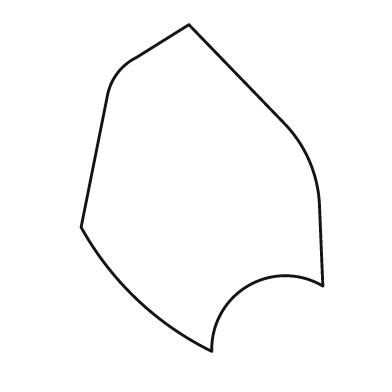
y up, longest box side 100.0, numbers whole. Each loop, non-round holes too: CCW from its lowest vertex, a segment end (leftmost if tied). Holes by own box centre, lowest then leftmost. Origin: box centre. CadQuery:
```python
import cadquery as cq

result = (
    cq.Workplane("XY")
    .moveTo(3.0, -50.0)
    .threePointArc((14.0, -30.0), (37.0, -30.0))
    .lineTo(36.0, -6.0)
    .threePointArc((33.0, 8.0), (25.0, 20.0))
    .lineTo(-4.0, 50.0)
    .lineTo(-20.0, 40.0)
    .threePointArc((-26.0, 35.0), (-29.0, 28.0))
    .lineTo(-37.0, -12.0)
    .threePointArc((-20.0, -34.0), (3.0, -50.0))
    .close()
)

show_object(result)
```